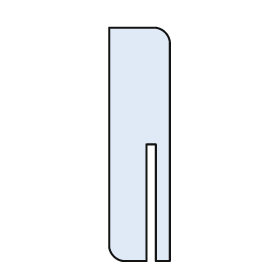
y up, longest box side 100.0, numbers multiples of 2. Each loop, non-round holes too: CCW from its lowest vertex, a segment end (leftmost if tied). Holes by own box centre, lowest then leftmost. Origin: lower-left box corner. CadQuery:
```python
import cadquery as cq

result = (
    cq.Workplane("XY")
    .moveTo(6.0, 0.0)
    .lineTo(16.0, 0.0)
    .lineTo(16.0, 50.0)
    .lineTo(20.0, 50.0)
    .lineTo(20.0, 0.0)
    .lineTo(26.0, 0.0)
    .lineTo(26.0, 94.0)
    .threePointArc((24.0, 98.0), (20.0, 100.0))
    .lineTo(0.0, 100.0)
    .lineTo(0.0, 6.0)
    .threePointArc((2.0, 2.0), (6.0, 0.0))
    .close()
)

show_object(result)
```